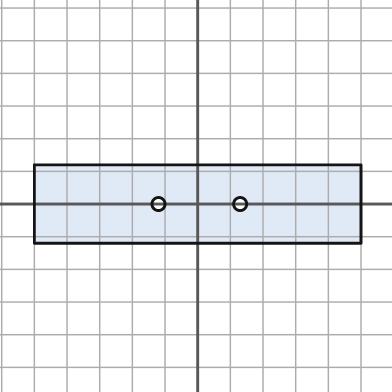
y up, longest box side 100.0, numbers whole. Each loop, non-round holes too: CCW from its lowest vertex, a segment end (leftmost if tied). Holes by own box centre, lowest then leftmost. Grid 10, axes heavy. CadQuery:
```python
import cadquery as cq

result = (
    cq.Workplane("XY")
    .moveTo(-50.0, -12.0)
    .lineTo(50.0, -12.0)
    .lineTo(50.0, 12.0)
    .lineTo(-50.0, 12.0)
    .close()
    .moveTo(-12.0, 0.0)
    .circle(2.0)
    .moveTo(13.0, 0.0)
    .circle(2.0)
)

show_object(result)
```